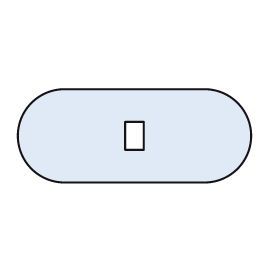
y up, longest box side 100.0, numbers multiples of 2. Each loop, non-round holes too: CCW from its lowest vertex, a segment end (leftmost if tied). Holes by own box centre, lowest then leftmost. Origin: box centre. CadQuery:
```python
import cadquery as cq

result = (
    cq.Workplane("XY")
    .moveTo(-30.0, -20.0)
    .lineTo(30.0, -20.0)
    .threePointArc((50.0, 0.0), (30.0, 20.0))
    .lineTo(-30.0, 20.0)
    .threePointArc((-50.0, 0.0), (-30.0, -20.0))
    .close()
    .moveTo(-4.0, -6.0)
    .lineTo(4.0, -6.0)
    .lineTo(4.0, 6.0)
    .lineTo(-4.0, 6.0)
    .close()
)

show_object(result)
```